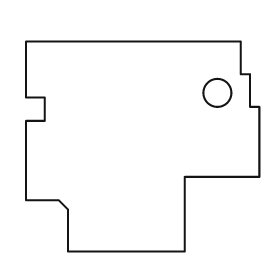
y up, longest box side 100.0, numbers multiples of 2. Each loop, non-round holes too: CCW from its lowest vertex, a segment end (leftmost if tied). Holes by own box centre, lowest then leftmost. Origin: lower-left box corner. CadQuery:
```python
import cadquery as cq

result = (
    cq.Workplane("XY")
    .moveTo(18.0, 0.0)
    .lineTo(68.0, 0.0)
    .lineTo(68.0, 32.0)
    .lineTo(100.0, 32.0)
    .lineTo(100.0, 62.0)
    .lineTo(96.0, 62.0)
    .lineTo(96.0, 76.0)
    .lineTo(92.0, 76.0)
    .lineTo(92.0, 90.0)
    .lineTo(0.0, 90.0)
    .lineTo(0.0, 66.0)
    .lineTo(8.0, 66.0)
    .lineTo(8.0, 56.0)
    .lineTo(0.0, 56.0)
    .lineTo(0.0, 22.0)
    .lineTo(14.0, 22.0)
    .lineTo(18.0, 18.0)
    .close()
    .moveTo(82.0, 68.0)
    .circle(6.0)
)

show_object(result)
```